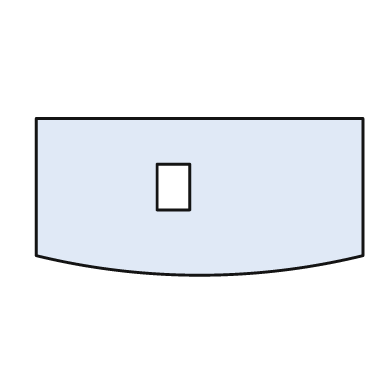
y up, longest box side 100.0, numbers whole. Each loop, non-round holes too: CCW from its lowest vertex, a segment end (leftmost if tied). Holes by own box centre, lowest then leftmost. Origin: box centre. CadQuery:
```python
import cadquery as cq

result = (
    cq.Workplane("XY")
    .moveTo(-50.0, -18.0)
    .threePointArc((0.0, -24.0), (50.0, -18.0))
    .lineTo(50.0, 24.0)
    .lineTo(-50.0, 24.0)
    .close()
    .moveTo(-13.0, -4.0)
    .lineTo(-3.0, -4.0)
    .lineTo(-3.0, 10.0)
    .lineTo(-13.0, 10.0)
    .close()
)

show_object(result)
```